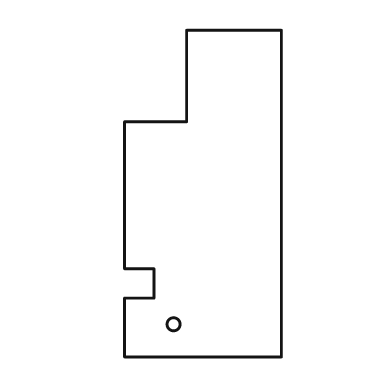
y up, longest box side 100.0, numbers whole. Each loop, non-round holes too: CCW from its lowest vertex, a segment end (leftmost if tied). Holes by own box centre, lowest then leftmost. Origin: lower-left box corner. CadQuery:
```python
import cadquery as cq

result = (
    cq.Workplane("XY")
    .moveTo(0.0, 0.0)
    .lineTo(48.0, 0.0)
    .lineTo(48.0, 100.0)
    .lineTo(19.0, 100.0)
    .lineTo(19.0, 72.0)
    .lineTo(0.0, 72.0)
    .lineTo(0.0, 27.0)
    .lineTo(9.0, 27.0)
    .lineTo(9.0, 18.0)
    .lineTo(0.0, 18.0)
    .close()
    .moveTo(15.0, 10.0)
    .circle(2.0)
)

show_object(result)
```